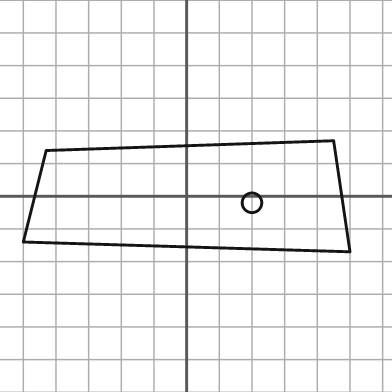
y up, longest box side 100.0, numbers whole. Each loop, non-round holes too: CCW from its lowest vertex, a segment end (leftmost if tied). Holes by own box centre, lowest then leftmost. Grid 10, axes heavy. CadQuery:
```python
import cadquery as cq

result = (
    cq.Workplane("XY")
    .moveTo(50.0, -17.0)
    .lineTo(45.0, 17.0)
    .lineTo(-43.0, 14.0)
    .lineTo(-50.0, -14.0)
    .close()
    .moveTo(20.0, -2.0)
    .circle(3.0)
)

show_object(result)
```